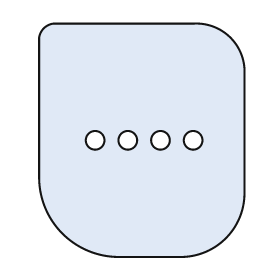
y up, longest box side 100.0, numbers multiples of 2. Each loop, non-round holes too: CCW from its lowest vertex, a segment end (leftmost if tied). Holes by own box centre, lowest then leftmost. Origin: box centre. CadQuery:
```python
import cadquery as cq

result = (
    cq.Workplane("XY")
    .moveTo(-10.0, -50.0)
    .lineTo(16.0, -50.0)
    .threePointArc((36.0, -42.0), (44.0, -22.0))
    .lineTo(44.0, 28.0)
    .threePointArc((38.0, 44.0), (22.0, 50.0))
    .lineTo(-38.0, 50.0)
    .threePointArc((-42.0, 48.0), (-44.0, 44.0))
    .lineTo(-44.0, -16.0)
    .threePointArc((-34.0, -40.0), (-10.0, -50.0))
    .close()
    .moveTo(-20.0, 0.0)
    .circle(4.0)
    .moveTo(-6.0, 0.0)
    .circle(4.0)
    .moveTo(8.0, 0.0)
    .circle(4.0)
    .moveTo(22.0, 0.0)
    .circle(4.0)
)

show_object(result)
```